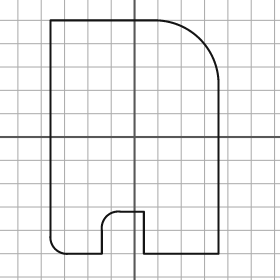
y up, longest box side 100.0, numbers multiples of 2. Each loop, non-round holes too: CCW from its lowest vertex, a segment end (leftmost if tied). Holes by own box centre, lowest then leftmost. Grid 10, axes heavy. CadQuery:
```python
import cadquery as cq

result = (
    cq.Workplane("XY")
    .moveTo(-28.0, -50.0)
    .lineTo(-14.0, -50.0)
    .lineTo(-14.0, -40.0)
    .threePointArc((-12.0, -34.0), (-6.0, -32.0))
    .lineTo(4.0, -32.0)
    .lineTo(4.0, -50.0)
    .lineTo(36.0, -50.0)
    .lineTo(36.0, 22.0)
    .threePointArc((28.0, 42.0), (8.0, 50.0))
    .lineTo(-36.0, 50.0)
    .lineTo(-36.0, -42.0)
    .threePointArc((-34.0, -48.0), (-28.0, -50.0))
    .close()
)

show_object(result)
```